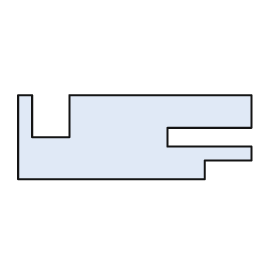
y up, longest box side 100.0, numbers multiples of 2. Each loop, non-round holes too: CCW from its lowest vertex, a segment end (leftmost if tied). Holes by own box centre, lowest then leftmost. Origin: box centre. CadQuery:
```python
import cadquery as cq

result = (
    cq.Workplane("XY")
    .moveTo(-50.0, -18.0)
    .lineTo(30.0, -18.0)
    .lineTo(30.0, -10.0)
    .lineTo(50.0, -10.0)
    .lineTo(50.0, -4.0)
    .lineTo(14.0, -4.0)
    .lineTo(14.0, 4.0)
    .lineTo(50.0, 4.0)
    .lineTo(50.0, 18.0)
    .lineTo(-28.0, 18.0)
    .lineTo(-28.0, 0.0)
    .lineTo(-44.0, 0.0)
    .lineTo(-44.0, 18.0)
    .lineTo(-50.0, 18.0)
    .close()
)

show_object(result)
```